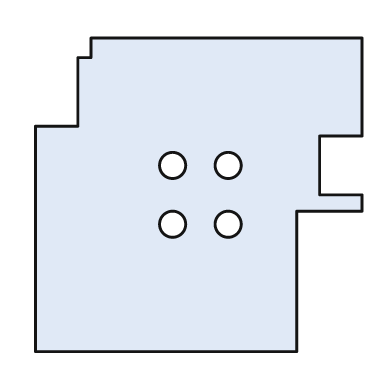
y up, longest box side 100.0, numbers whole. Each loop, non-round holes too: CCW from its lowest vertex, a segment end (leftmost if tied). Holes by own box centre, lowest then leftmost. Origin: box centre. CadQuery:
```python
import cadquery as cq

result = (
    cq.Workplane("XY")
    .moveTo(-50.0, -48.0)
    .lineTo(30.0, -48.0)
    .lineTo(30.0, -5.0)
    .lineTo(50.0, -5.0)
    .lineTo(50.0, 0.0)
    .lineTo(37.0, 0.0)
    .lineTo(37.0, 18.0)
    .lineTo(50.0, 18.0)
    .lineTo(50.0, 48.0)
    .lineTo(-33.0, 48.0)
    .lineTo(-33.0, 42.0)
    .lineTo(-37.0, 42.0)
    .lineTo(-37.0, 21.0)
    .lineTo(-50.0, 21.0)
    .close()
    .moveTo(-8.0, -9.0)
    .circle(4.0)
    .moveTo(9.0, -9.0)
    .circle(4.0)
    .moveTo(-8.0, 9.0)
    .circle(4.0)
    .moveTo(9.0, 9.0)
    .circle(4.0)
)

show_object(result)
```